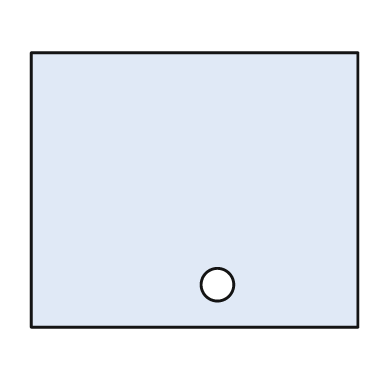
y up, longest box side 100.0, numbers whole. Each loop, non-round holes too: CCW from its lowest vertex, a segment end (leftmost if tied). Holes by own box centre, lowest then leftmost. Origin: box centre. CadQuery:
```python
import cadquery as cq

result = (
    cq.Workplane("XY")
    .moveTo(-50.0, -42.0)
    .lineTo(50.0, -42.0)
    .lineTo(50.0, 42.0)
    .lineTo(-50.0, 42.0)
    .close()
    .moveTo(7.0, -29.0)
    .circle(5.0)
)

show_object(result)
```